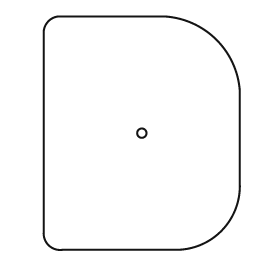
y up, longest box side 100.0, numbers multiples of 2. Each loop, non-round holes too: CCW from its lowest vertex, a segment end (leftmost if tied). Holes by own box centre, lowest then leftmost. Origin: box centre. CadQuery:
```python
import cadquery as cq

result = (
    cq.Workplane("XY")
    .moveTo(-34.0, -50.0)
    .lineTo(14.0, -50.0)
    .threePointArc((34.0, -42.0), (42.0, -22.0))
    .lineTo(42.0, 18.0)
    .threePointArc((32.0, 40.0), (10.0, 50.0))
    .lineTo(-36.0, 50.0)
    .threePointArc((-40.0, 48.0), (-42.0, 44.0))
    .lineTo(-42.0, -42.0)
    .threePointArc((-40.0, -48.0), (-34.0, -50.0))
    .close()
    .moveTo(0.0, 0.0)
    .circle(2.0)
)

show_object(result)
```